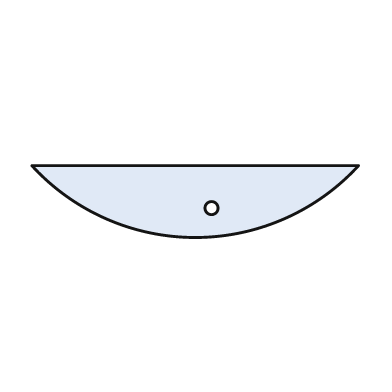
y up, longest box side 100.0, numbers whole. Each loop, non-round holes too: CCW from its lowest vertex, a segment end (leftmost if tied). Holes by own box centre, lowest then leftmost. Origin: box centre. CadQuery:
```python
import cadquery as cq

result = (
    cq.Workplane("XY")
    .moveTo(-50.0, 11.0)
    .threePointArc((0.0, -11.0), (50.0, 11.0))
    .close()
    .moveTo(5.0, -2.0)
    .circle(2.0)
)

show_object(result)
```